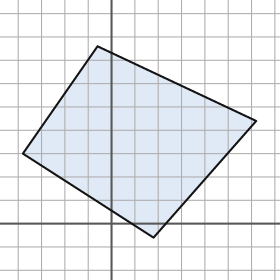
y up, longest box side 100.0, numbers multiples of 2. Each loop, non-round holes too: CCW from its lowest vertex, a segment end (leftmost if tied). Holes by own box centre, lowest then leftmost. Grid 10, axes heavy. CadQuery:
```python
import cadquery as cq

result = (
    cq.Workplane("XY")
    .moveTo(18.0, -6.0)
    .lineTo(62.0, 44.0)
    .lineTo(-6.0, 76.0)
    .lineTo(-38.0, 30.0)
    .close()
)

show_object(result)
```